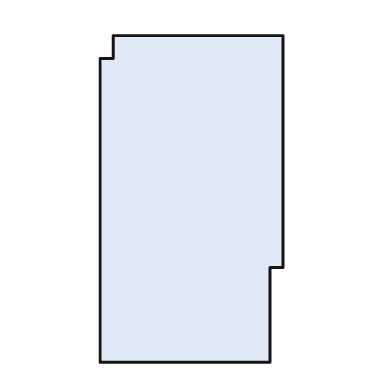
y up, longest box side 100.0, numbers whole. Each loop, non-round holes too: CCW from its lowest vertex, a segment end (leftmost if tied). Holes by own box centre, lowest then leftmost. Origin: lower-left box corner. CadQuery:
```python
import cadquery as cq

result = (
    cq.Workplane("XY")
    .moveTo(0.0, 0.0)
    .lineTo(52.0, 0.0)
    .lineTo(52.0, 29.0)
    .lineTo(56.0, 29.0)
    .lineTo(56.0, 100.0)
    .lineTo(4.0, 100.0)
    .lineTo(4.0, 93.0)
    .lineTo(0.0, 93.0)
    .close()
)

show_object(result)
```